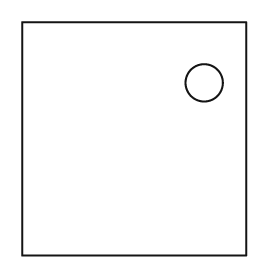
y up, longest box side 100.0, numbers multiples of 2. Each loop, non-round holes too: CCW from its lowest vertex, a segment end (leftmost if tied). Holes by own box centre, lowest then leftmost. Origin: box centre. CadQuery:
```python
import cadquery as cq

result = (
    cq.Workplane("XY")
    .moveTo(-48.0, -50.0)
    .lineTo(48.0, -50.0)
    .lineTo(48.0, 50.0)
    .lineTo(-48.0, 50.0)
    .close()
    .moveTo(30.0, 24.0)
    .circle(8.0)
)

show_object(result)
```